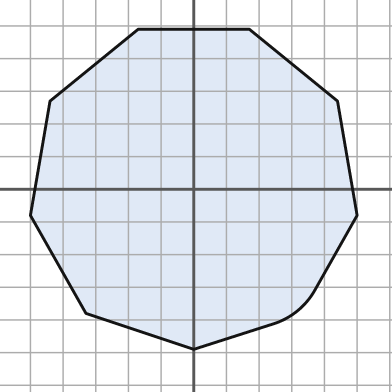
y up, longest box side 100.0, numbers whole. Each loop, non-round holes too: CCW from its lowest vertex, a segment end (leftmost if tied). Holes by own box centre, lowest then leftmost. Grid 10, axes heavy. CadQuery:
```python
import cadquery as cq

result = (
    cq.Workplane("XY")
    .moveTo(0.0, -49.0)
    .lineTo(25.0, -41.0)
    .threePointArc((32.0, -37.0), (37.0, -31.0))
    .lineTo(50.0, -8.0)
    .lineTo(44.0, 27.0)
    .lineTo(17.0, 49.0)
    .lineTo(-17.0, 49.0)
    .lineTo(-44.0, 27.0)
    .lineTo(-50.0, -8.0)
    .lineTo(-33.0, -38.0)
    .close()
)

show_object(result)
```